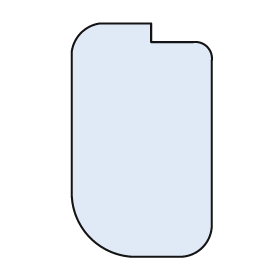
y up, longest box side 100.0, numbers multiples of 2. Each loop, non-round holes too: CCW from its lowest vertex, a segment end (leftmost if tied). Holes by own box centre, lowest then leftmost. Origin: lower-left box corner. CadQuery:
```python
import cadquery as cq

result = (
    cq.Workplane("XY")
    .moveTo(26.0, 0.0)
    .lineTo(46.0, 0.0)
    .threePointArc((56.0, 4.0), (60.0, 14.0))
    .lineTo(60.0, 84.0)
    .threePointArc((58.0, 90.0), (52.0, 92.0))
    .lineTo(34.0, 92.0)
    .lineTo(34.0, 100.0)
    .lineTo(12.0, 100.0)
    .threePointArc((4.0, 96.0), (0.0, 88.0))
    .lineTo(0.0, 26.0)
    .threePointArc((8.0, 8.0), (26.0, 0.0))
    .close()
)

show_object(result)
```